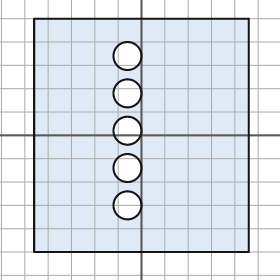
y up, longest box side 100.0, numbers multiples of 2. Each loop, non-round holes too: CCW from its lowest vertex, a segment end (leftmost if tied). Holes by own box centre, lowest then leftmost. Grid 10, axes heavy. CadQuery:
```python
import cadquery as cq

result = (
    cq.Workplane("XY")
    .moveTo(-46.0, -50.0)
    .lineTo(46.0, -50.0)
    .lineTo(46.0, 50.0)
    .lineTo(-46.0, 50.0)
    .close()
    .moveTo(-6.0, -30.0)
    .circle(6.0)
    .moveTo(-6.0, -14.0)
    .circle(6.0)
    .moveTo(-6.0, 2.0)
    .circle(6.0)
    .moveTo(-6.0, 18.0)
    .circle(6.0)
    .moveTo(-6.0, 34.0)
    .circle(6.0)
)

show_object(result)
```